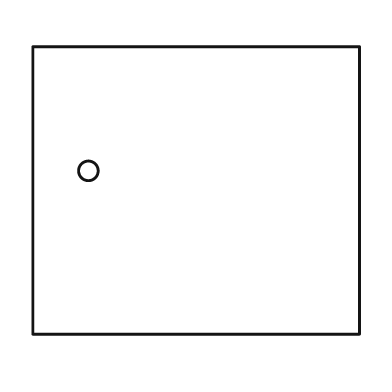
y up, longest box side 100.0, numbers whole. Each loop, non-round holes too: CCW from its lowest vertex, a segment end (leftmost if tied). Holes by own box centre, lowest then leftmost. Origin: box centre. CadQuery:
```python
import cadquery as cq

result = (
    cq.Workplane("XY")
    .moveTo(-50.0, -44.0)
    .lineTo(50.0, -44.0)
    .lineTo(50.0, 44.0)
    .lineTo(-50.0, 44.0)
    .close()
    .moveTo(-33.0, 6.0)
    .circle(3.0)
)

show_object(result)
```